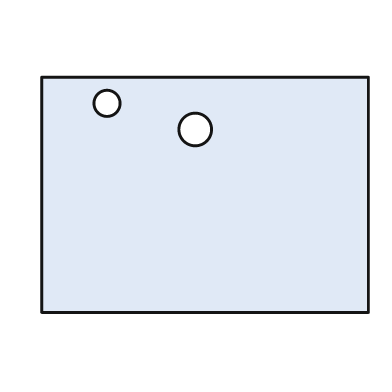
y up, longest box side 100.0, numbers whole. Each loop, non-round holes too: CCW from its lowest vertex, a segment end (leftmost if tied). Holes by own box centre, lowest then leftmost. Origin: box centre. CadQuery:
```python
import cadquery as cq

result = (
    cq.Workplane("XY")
    .moveTo(-50.0, -36.0)
    .lineTo(50.0, -36.0)
    .lineTo(50.0, 36.0)
    .lineTo(-50.0, 36.0)
    .close()
    .moveTo(-3.0, 20.0)
    .circle(5.0)
    .moveTo(-30.0, 28.0)
    .circle(4.0)
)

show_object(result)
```